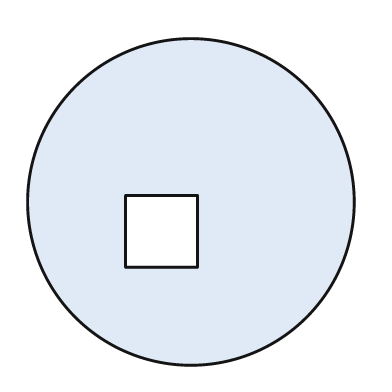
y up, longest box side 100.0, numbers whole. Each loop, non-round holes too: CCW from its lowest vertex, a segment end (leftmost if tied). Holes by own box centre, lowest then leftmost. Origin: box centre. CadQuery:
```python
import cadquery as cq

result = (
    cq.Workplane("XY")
    .moveTo(0.0, 0.0)
    .circle(50.0)
    .moveTo(-20.0, -20.0)
    .lineTo(2.0, -20.0)
    .lineTo(2.0, 2.0)
    .lineTo(-20.0, 2.0)
    .close()
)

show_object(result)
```